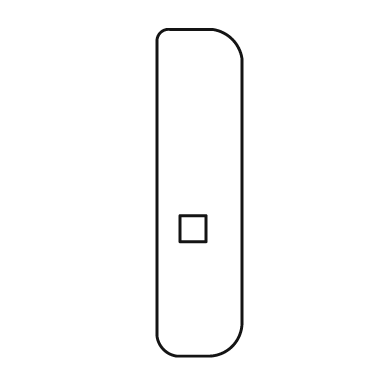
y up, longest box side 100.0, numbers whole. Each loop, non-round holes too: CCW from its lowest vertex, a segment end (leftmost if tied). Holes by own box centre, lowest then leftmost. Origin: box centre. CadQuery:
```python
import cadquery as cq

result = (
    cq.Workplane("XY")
    .moveTo(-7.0, -50.0)
    .lineTo(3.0, -50.0)
    .threePointArc((10.0, -47.0), (13.0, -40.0))
    .lineTo(13.0, 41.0)
    .threePointArc((10.0, 47.0), (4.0, 50.0))
    .lineTo(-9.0, 50.0)
    .threePointArc((-12.0, 49.0), (-13.0, 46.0))
    .lineTo(-13.0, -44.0)
    .threePointArc((-11.0, -48.0), (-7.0, -50.0))
    .close()
    .moveTo(-6.0, -15.0)
    .lineTo(2.0, -15.0)
    .lineTo(2.0, -7.0)
    .lineTo(-6.0, -7.0)
    .close()
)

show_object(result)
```